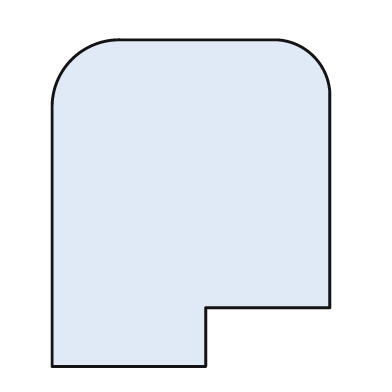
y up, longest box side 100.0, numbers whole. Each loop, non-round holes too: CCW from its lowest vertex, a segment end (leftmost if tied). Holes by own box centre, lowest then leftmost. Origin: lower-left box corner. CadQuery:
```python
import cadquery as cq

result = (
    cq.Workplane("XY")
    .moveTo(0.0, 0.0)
    .lineTo(47.0, 0.0)
    .lineTo(47.0, 18.0)
    .lineTo(85.0, 18.0)
    .lineTo(85.0, 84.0)
    .threePointArc((80.0, 95.0), (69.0, 100.0))
    .lineTo(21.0, 100.0)
    .threePointArc((6.0, 94.0), (0.0, 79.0))
    .close()
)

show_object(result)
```